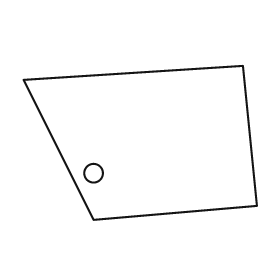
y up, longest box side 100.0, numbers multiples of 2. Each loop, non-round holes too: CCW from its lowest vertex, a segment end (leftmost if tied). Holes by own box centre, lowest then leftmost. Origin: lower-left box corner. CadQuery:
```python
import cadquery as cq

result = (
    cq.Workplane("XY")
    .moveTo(30.0, 0.0)
    .lineTo(100.0, 6.0)
    .lineTo(94.0, 66.0)
    .lineTo(0.0, 60.0)
    .close()
    .moveTo(30.0, 20.0)
    .circle(4.0)
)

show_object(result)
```